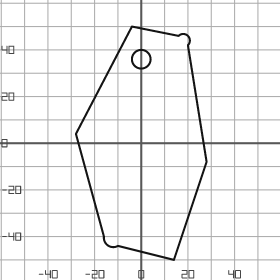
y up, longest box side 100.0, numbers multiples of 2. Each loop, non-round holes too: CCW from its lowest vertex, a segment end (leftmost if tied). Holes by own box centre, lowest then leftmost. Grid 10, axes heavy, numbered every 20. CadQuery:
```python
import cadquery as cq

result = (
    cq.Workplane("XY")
    .moveTo(14.0, -50.0)
    .lineTo(28.0, -8.0)
    .lineTo(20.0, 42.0)
    .threePointArc((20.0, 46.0), (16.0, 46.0))
    .lineTo(-4.0, 50.0)
    .lineTo(-28.0, 4.0)
    .lineTo(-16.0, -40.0)
    .threePointArc((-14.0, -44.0), (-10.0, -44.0))
    .close()
    .moveTo(0.0, 36.0)
    .circle(4.0)
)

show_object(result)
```